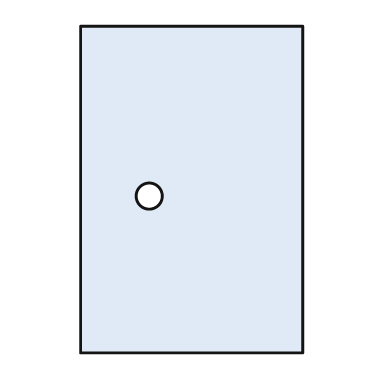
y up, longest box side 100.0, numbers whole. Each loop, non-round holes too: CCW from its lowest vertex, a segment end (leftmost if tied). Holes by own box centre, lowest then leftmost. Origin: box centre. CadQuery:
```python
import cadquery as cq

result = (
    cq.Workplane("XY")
    .moveTo(-34.0, -50.0)
    .lineTo(34.0, -50.0)
    .lineTo(34.0, 50.0)
    .lineTo(-34.0, 50.0)
    .close()
    .moveTo(-13.0, -2.0)
    .circle(4.0)
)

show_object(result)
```